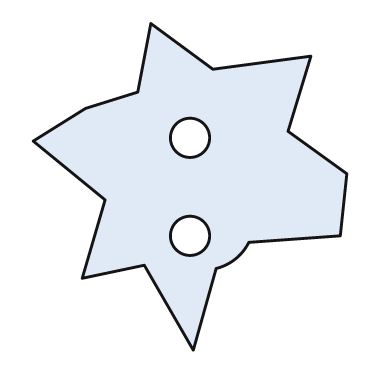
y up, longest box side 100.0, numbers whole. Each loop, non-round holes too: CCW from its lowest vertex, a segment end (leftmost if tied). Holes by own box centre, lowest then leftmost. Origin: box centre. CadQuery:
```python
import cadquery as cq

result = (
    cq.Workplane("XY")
    .moveTo(1.0, -50.0)
    .lineTo(8.0, -25.0)
    .threePointArc((14.0, -22.0), (18.0, -17.0))
    .lineTo(46.0, -15.0)
    .lineTo(48.0, 4.0)
    .lineTo(30.0, 17.0)
    .lineTo(37.0, 40.0)
    .lineTo(7.0, 36.0)
    .lineTo(-12.0, 50.0)
    .lineTo(-16.0, 29.0)
    .lineTo(-32.0, 24.0)
    .lineTo(-48.0, 14.0)
    .lineTo(-26.0, -4.0)
    .lineTo(-33.0, -28.0)
    .lineTo(-14.0, -24.0)
    .close()
    .moveTo(0.0, -15.0)
    .circle(6.0)
    .moveTo(0.0, 15.0)
    .circle(6.0)
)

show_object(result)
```